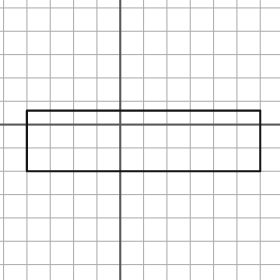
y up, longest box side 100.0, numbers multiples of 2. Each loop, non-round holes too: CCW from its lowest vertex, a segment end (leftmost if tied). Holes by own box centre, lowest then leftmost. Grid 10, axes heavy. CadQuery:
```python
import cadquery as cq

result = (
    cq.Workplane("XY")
    .moveTo(-40.0, -20.0)
    .lineTo(60.0, -20.0)
    .lineTo(60.0, 6.0)
    .lineTo(-40.0, 6.0)
    .close()
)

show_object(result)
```